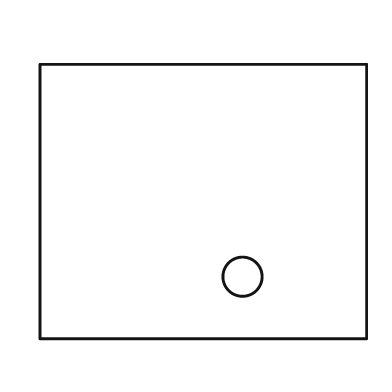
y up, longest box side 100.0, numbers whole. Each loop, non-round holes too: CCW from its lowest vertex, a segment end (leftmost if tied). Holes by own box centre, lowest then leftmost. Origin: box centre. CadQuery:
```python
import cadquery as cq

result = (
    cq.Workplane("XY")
    .moveTo(-50.0, -42.0)
    .lineTo(50.0, -42.0)
    .lineTo(50.0, 42.0)
    .lineTo(-50.0, 42.0)
    .close()
    .moveTo(12.0, -23.0)
    .circle(6.0)
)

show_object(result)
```